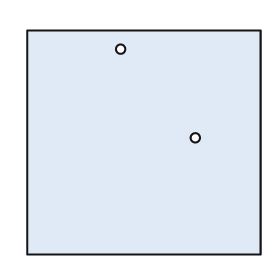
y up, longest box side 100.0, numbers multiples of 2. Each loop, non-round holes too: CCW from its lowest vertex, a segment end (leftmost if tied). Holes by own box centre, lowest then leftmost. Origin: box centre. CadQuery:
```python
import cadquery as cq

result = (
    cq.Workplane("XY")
    .moveTo(-50.0, -48.0)
    .lineTo(50.0, -48.0)
    .lineTo(50.0, 48.0)
    .lineTo(-50.0, 48.0)
    .close()
    .moveTo(22.0, 2.0)
    .circle(2.0)
    .moveTo(-10.0, 40.0)
    .circle(2.0)
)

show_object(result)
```